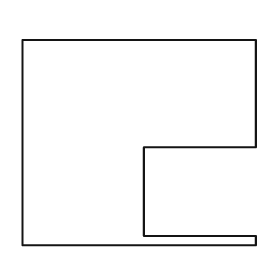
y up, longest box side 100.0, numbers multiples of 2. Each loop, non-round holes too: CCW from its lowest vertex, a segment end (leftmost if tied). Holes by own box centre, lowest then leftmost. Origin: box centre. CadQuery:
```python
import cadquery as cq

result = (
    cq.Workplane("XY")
    .moveTo(-50.0, -44.0)
    .lineTo(50.0, -44.0)
    .lineTo(50.0, -40.0)
    .lineTo(2.0, -40.0)
    .lineTo(2.0, -2.0)
    .lineTo(50.0, -2.0)
    .lineTo(50.0, 44.0)
    .lineTo(-50.0, 44.0)
    .close()
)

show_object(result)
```